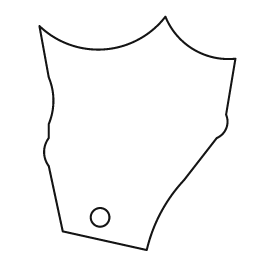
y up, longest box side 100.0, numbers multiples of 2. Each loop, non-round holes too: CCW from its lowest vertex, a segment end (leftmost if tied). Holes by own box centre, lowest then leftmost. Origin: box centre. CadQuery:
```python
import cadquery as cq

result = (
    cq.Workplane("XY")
    .moveTo(4.0, -50.0)
    .threePointArc((10.0, -34.0), (20.0, -20.0))
    .lineTo(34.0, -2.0)
    .threePointArc((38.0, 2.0), (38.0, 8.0))
    .lineTo(42.0, 32.0)
    .threePointArc((24.0, 36.0), (12.0, 50.0))
    .threePointArc((-14.0, 36.0), (-42.0, 46.0))
    .lineTo(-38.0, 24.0)
    .threePointArc((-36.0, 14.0), (-38.0, 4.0))
    .lineTo(-38.0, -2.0)
    .threePointArc((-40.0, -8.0), (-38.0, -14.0))
    .lineTo(-32.0, -42.0)
    .close()
    .moveTo(-16.0, -36.0)
    .circle(4.0)
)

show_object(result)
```